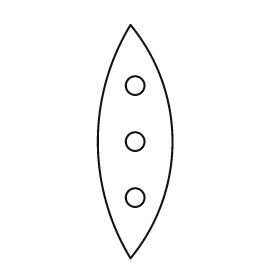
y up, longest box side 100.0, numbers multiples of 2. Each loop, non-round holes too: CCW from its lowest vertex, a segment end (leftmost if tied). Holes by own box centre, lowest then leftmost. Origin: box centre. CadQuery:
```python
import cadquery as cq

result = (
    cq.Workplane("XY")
    .moveTo(-2.0, -50.0)
    .threePointArc((16.0, 0.0), (-2.0, 50.0))
    .threePointArc((-16.0, 0.0), (-2.0, -50.0))
    .close()
    .moveTo(0.0, -24.0)
    .circle(4.0)
    .moveTo(0.0, 0.0)
    .circle(4.0)
    .moveTo(0.0, 24.0)
    .circle(4.0)
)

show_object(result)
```